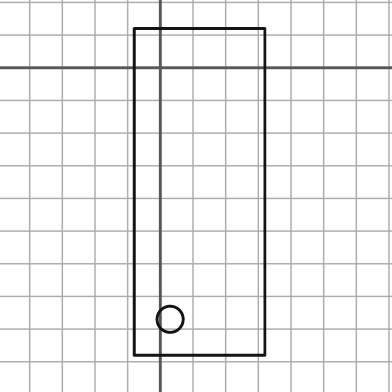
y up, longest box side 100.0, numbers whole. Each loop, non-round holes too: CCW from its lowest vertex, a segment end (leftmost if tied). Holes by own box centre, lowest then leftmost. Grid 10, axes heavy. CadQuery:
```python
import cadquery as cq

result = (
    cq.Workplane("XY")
    .moveTo(-8.0, -88.0)
    .lineTo(32.0, -88.0)
    .lineTo(32.0, 12.0)
    .lineTo(-8.0, 12.0)
    .close()
    .moveTo(3.0, -77.0)
    .circle(4.0)
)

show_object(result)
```